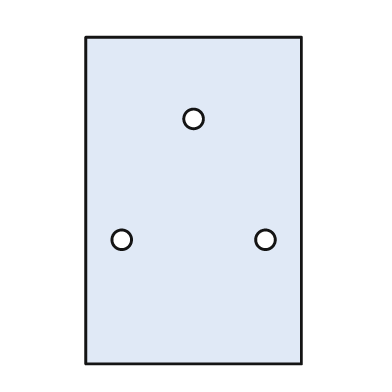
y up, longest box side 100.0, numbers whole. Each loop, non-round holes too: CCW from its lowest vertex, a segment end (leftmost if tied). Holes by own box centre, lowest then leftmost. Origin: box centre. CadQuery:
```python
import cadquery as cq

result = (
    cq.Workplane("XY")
    .moveTo(-33.0, -50.0)
    .lineTo(33.0, -50.0)
    .lineTo(33.0, 50.0)
    .lineTo(-33.0, 50.0)
    .close()
    .moveTo(-22.0, -12.0)
    .circle(3.0)
    .moveTo(22.0, -12.0)
    .circle(3.0)
    .moveTo(0.0, 25.0)
    .circle(3.0)
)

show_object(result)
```